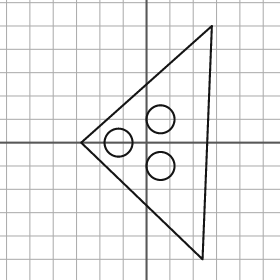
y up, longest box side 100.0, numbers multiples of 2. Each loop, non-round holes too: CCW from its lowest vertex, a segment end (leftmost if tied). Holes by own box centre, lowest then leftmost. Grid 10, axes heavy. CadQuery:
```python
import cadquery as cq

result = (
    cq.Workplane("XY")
    .moveTo(24.0, -50.0)
    .lineTo(28.0, 50.0)
    .lineTo(-28.0, 0.0)
    .close()
    .moveTo(6.0, -10.0)
    .circle(6.0)
    .moveTo(-12.0, 0.0)
    .circle(6.0)
    .moveTo(6.0, 10.0)
    .circle(6.0)
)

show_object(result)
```